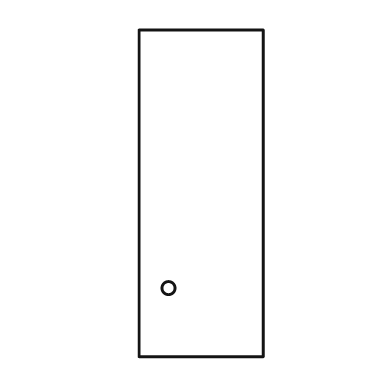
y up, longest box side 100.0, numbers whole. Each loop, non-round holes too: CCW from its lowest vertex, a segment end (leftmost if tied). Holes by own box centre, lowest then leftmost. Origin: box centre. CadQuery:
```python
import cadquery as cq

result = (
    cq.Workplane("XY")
    .moveTo(-19.0, -50.0)
    .lineTo(19.0, -50.0)
    .lineTo(19.0, 50.0)
    .lineTo(-19.0, 50.0)
    .close()
    .moveTo(-10.0, -29.0)
    .circle(2.0)
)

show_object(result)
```